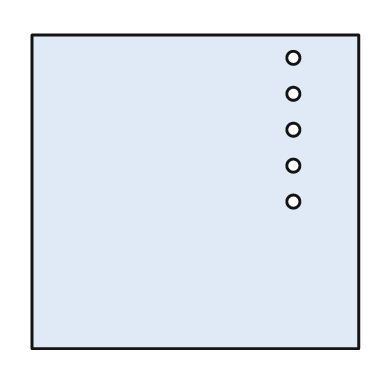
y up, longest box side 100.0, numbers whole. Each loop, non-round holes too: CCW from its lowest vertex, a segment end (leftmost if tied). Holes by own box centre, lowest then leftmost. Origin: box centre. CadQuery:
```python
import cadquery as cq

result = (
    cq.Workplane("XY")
    .moveTo(-50.0, -48.0)
    .lineTo(50.0, -48.0)
    .lineTo(50.0, 48.0)
    .lineTo(-50.0, 48.0)
    .close()
    .moveTo(30.0, -3.0)
    .circle(2.0)
    .moveTo(30.0, 8.0)
    .circle(2.0)
    .moveTo(30.0, 19.0)
    .circle(2.0)
    .moveTo(30.0, 30.0)
    .circle(2.0)
    .moveTo(30.0, 41.0)
    .circle(2.0)
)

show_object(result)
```